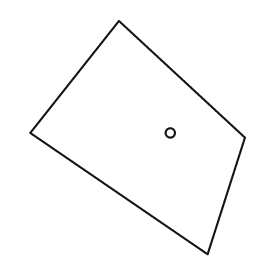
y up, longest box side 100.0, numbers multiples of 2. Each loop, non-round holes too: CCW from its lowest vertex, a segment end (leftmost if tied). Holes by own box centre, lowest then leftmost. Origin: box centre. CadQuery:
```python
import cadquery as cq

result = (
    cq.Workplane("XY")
    .moveTo(30.0, -50.0)
    .lineTo(46.0, 0.0)
    .lineTo(-8.0, 50.0)
    .lineTo(-46.0, 2.0)
    .close()
    .moveTo(14.0, 2.0)
    .circle(2.0)
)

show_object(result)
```